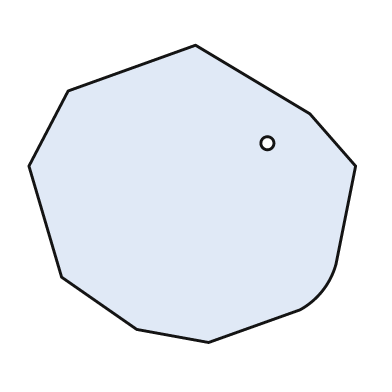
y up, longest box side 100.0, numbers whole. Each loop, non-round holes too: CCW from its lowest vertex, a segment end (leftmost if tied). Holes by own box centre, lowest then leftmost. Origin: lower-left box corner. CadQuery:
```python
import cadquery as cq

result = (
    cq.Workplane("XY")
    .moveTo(55.0, 0.0)
    .lineTo(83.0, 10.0)
    .threePointArc((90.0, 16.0), (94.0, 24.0))
    .lineTo(100.0, 54.0)
    .lineTo(86.0, 70.0)
    .lineTo(51.0, 91.0)
    .lineTo(12.0, 77.0)
    .lineTo(0.0, 54.0)
    .lineTo(10.0, 20.0)
    .lineTo(33.0, 4.0)
    .close()
    .moveTo(73.0, 61.0)
    .circle(2.0)
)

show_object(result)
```